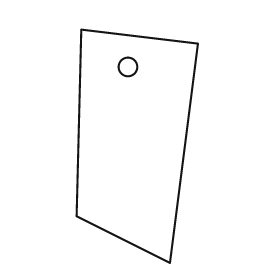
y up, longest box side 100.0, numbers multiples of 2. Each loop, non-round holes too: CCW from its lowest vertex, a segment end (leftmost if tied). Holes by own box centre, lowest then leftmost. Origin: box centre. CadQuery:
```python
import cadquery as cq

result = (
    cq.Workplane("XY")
    .moveTo(14.0, -50.0)
    .lineTo(26.0, 44.0)
    .lineTo(-24.0, 50.0)
    .lineTo(-26.0, -30.0)
    .close()
    .moveTo(-4.0, 34.0)
    .circle(4.0)
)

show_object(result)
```